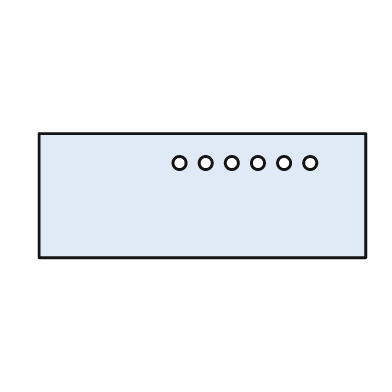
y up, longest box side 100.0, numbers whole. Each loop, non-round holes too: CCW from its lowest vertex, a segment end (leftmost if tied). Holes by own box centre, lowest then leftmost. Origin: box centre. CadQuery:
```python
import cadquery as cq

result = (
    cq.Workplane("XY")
    .moveTo(-50.0, -19.0)
    .lineTo(50.0, -19.0)
    .lineTo(50.0, 19.0)
    .lineTo(-50.0, 19.0)
    .close()
    .moveTo(-7.0, 10.0)
    .circle(2.0)
    .moveTo(1.0, 10.0)
    .circle(2.0)
    .moveTo(9.0, 10.0)
    .circle(2.0)
    .moveTo(17.0, 10.0)
    .circle(2.0)
    .moveTo(25.0, 10.0)
    .circle(2.0)
    .moveTo(33.0, 10.0)
    .circle(2.0)
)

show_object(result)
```